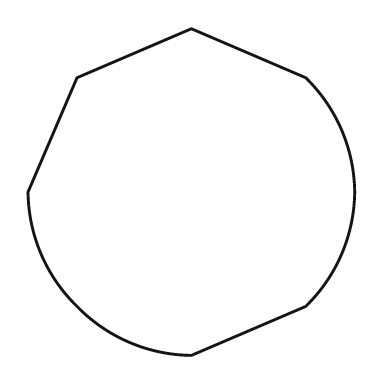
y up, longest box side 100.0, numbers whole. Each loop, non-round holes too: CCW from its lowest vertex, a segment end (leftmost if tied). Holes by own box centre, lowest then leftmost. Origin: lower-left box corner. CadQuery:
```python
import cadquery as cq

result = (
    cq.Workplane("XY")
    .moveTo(50.0, 0.0)
    .lineTo(85.0, 15.0)
    .threePointArc((96.0, 31.0), (100.0, 50.0))
    .threePointArc((96.0, 69.0), (85.0, 85.0))
    .lineTo(50.0, 100.0)
    .lineTo(15.0, 85.0)
    .lineTo(0.0, 50.0)
    .threePointArc((4.0, 31.0), (15.0, 15.0))
    .threePointArc((31.0, 4.0), (50.0, 0.0))
    .close()
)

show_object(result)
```